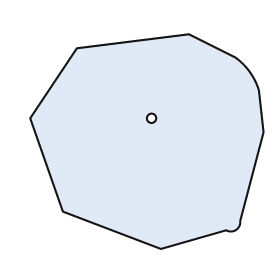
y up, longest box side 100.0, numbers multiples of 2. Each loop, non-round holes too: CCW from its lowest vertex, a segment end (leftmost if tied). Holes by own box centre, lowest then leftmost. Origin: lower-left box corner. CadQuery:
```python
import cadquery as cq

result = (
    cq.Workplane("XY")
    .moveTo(56.0, 0.0)
    .lineTo(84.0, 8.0)
    .threePointArc((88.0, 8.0), (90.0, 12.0))
    .lineTo(100.0, 50.0)
    .lineTo(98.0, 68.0)
    .threePointArc((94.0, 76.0), (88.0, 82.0))
    .lineTo(68.0, 92.0)
    .lineTo(20.0, 86.0)
    .lineTo(0.0, 56.0)
    .lineTo(14.0, 16.0)
    .close()
    .moveTo(52.0, 56.0)
    .circle(2.0)
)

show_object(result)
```